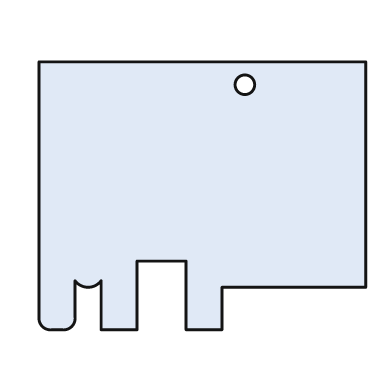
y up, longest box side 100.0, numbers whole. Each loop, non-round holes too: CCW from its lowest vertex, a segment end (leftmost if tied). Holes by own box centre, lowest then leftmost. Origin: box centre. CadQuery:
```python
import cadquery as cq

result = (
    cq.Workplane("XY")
    .moveTo(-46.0, -41.0)
    .lineTo(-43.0, -41.0)
    .threePointArc((-40.0, -40.0), (-39.0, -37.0))
    .lineTo(-39.0, -26.0)
    .threePointArc((-35.0, -28.0), (-31.0, -26.0))
    .lineTo(-31.0, -41.0)
    .lineTo(-20.0, -41.0)
    .lineTo(-20.0, -20.0)
    .lineTo(-5.0, -20.0)
    .lineTo(-5.0, -41.0)
    .lineTo(6.0, -41.0)
    .lineTo(6.0, -28.0)
    .lineTo(50.0, -28.0)
    .lineTo(50.0, 41.0)
    .lineTo(-50.0, 41.0)
    .lineTo(-50.0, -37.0)
    .threePointArc((-49.0, -40.0), (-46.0, -41.0))
    .close()
    .moveTo(13.0, 34.0)
    .circle(3.0)
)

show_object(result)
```